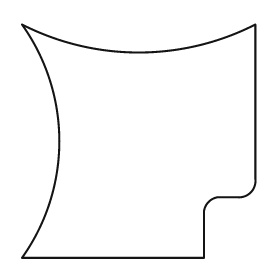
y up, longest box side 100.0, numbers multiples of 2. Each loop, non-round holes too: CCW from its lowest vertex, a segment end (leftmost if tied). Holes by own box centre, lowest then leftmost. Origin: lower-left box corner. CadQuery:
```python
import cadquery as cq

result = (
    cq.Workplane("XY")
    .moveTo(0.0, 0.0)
    .lineTo(78.0, 0.0)
    .lineTo(78.0, 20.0)
    .threePointArc((80.0, 24.0), (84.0, 26.0))
    .lineTo(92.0, 26.0)
    .threePointArc((98.0, 28.0), (100.0, 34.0))
    .lineTo(100.0, 100.0)
    .threePointArc((50.0, 88.0), (0.0, 100.0))
    .threePointArc((16.0, 50.0), (0.0, 0.0))
    .close()
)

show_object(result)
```